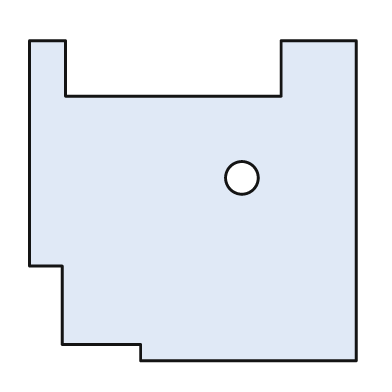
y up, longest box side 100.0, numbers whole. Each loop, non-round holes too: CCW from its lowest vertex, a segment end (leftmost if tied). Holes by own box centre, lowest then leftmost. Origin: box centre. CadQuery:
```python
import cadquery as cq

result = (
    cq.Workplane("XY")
    .moveTo(-16.0, -49.0)
    .lineTo(50.0, -49.0)
    .lineTo(50.0, 49.0)
    .lineTo(27.0, 49.0)
    .lineTo(27.0, 32.0)
    .lineTo(-39.0, 32.0)
    .lineTo(-39.0, 49.0)
    .lineTo(-50.0, 49.0)
    .lineTo(-50.0, -20.0)
    .lineTo(-40.0, -20.0)
    .lineTo(-40.0, -44.0)
    .lineTo(-16.0, -44.0)
    .close()
    .moveTo(15.0, 7.0)
    .circle(5.0)
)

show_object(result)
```